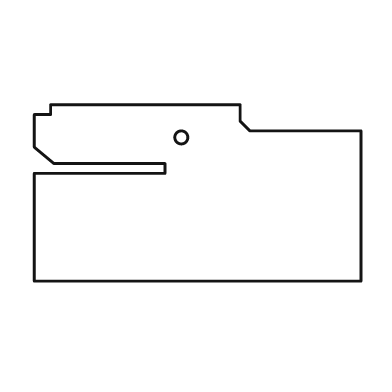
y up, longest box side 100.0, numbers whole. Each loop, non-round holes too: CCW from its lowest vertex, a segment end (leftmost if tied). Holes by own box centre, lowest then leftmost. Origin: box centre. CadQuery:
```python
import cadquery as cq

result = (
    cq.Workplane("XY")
    .moveTo(-50.0, -27.0)
    .lineTo(50.0, -27.0)
    .lineTo(50.0, 19.0)
    .lineTo(16.0, 19.0)
    .lineTo(13.0, 22.0)
    .lineTo(13.0, 27.0)
    .lineTo(-45.0, 27.0)
    .lineTo(-45.0, 24.0)
    .lineTo(-50.0, 24.0)
    .lineTo(-50.0, 14.0)
    .lineTo(-44.0, 9.0)
    .lineTo(-10.0, 9.0)
    .lineTo(-10.0, 6.0)
    .lineTo(-50.0, 6.0)
    .close()
    .moveTo(-5.0, 17.0)
    .circle(2.0)
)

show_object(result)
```